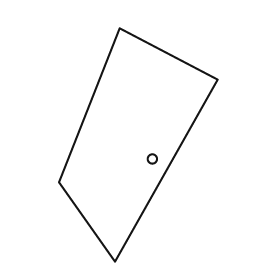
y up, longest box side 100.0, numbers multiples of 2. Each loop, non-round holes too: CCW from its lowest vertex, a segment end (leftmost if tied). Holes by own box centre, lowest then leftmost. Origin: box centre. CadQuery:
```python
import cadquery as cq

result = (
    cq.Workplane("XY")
    .moveTo(-10.0, -50.0)
    .lineTo(34.0, 28.0)
    .lineTo(-8.0, 50.0)
    .lineTo(-34.0, -16.0)
    .close()
    .moveTo(6.0, -6.0)
    .circle(2.0)
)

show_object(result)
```